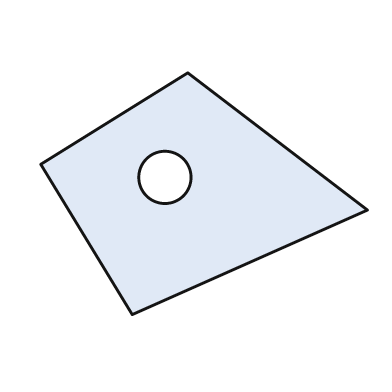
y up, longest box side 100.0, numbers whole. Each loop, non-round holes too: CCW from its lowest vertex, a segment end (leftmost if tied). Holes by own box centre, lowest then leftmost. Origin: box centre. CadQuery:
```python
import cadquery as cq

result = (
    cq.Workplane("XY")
    .moveTo(-22.0, -37.0)
    .lineTo(50.0, -5.0)
    .lineTo(-5.0, 37.0)
    .lineTo(-50.0, 9.0)
    .close()
    .moveTo(-12.0, 5.0)
    .circle(8.0)
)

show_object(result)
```